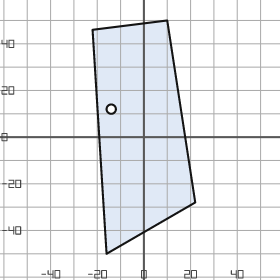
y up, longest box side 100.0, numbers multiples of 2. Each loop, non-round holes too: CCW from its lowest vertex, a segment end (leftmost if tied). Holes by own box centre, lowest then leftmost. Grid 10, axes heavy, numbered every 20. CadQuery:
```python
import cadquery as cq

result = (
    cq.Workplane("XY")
    .moveTo(-16.0, -50.0)
    .lineTo(22.0, -28.0)
    .lineTo(10.0, 50.0)
    .lineTo(-22.0, 46.0)
    .close()
    .moveTo(-14.0, 12.0)
    .circle(2.0)
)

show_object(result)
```